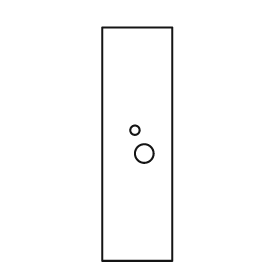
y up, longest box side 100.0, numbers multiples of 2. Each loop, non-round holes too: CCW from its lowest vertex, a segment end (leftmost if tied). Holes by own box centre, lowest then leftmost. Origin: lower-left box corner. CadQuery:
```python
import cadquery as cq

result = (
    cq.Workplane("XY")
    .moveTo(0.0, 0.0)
    .lineTo(30.0, 0.0)
    .lineTo(30.0, 100.0)
    .lineTo(0.0, 100.0)
    .close()
    .moveTo(18.0, 46.0)
    .circle(4.0)
    .moveTo(14.0, 56.0)
    .circle(2.0)
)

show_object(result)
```